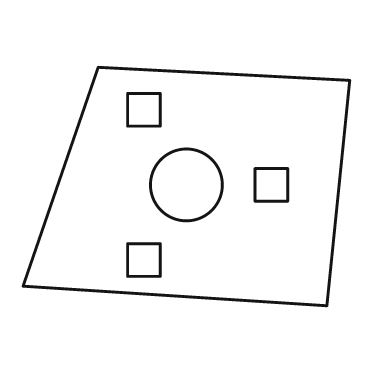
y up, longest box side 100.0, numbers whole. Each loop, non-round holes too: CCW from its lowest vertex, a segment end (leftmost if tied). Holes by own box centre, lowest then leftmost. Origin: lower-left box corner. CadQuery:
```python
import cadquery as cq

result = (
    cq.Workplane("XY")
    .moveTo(93.0, 0.0)
    .lineTo(100.0, 69.0)
    .lineTo(23.0, 73.0)
    .lineTo(0.0, 6.0)
    .close()
    .moveTo(32.0, 9.0)
    .lineTo(42.0, 9.0)
    .lineTo(42.0, 19.0)
    .lineTo(32.0, 19.0)
    .close()
    .moveTo(50.0, 37.0)
    .circle(11.0)
    .moveTo(71.0, 32.0)
    .lineTo(81.0, 32.0)
    .lineTo(81.0, 42.0)
    .lineTo(71.0, 42.0)
    .close()
    .moveTo(32.0, 55.0)
    .lineTo(42.0, 55.0)
    .lineTo(42.0, 65.0)
    .lineTo(32.0, 65.0)
    .close()
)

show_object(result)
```